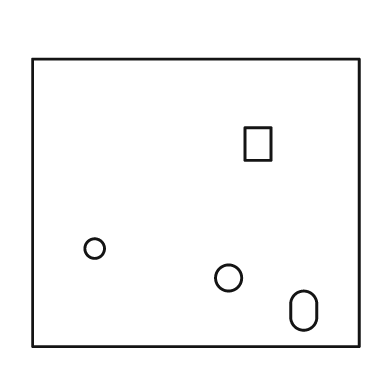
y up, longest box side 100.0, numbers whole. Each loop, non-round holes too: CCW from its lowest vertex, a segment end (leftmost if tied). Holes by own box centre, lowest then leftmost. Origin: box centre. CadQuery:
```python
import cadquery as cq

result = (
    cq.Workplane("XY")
    .moveTo(-50.0, -44.0)
    .lineTo(50.0, -44.0)
    .lineTo(50.0, 44.0)
    .lineTo(-50.0, 44.0)
    .close()
    .moveTo(29.0, -35.0)
    .threePointArc((33.0, -39.0), (37.0, -35.0))
    .lineTo(37.0, -31.0)
    .threePointArc((33.0, -27.0), (29.0, -31.0))
    .close()
    .moveTo(10.0, -23.0)
    .circle(4.0)
    .moveTo(-31.0, -14.0)
    .circle(3.0)
    .moveTo(15.0, 13.0)
    .lineTo(23.0, 13.0)
    .lineTo(23.0, 23.0)
    .lineTo(15.0, 23.0)
    .close()
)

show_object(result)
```